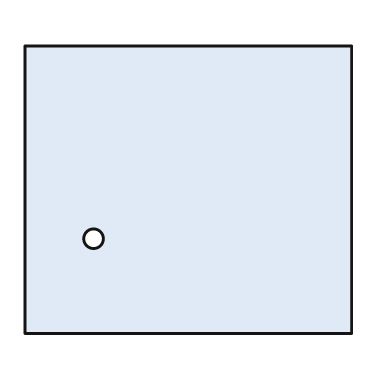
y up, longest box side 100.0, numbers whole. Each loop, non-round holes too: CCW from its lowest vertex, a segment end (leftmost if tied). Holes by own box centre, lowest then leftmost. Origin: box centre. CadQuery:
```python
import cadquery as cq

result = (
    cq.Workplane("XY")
    .moveTo(-50.0, -44.0)
    .lineTo(50.0, -44.0)
    .lineTo(50.0, 44.0)
    .lineTo(-50.0, 44.0)
    .close()
    .moveTo(-29.0, -15.0)
    .circle(3.0)
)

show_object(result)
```